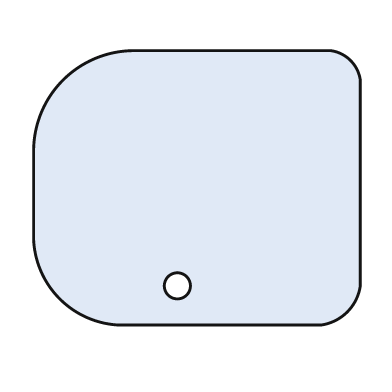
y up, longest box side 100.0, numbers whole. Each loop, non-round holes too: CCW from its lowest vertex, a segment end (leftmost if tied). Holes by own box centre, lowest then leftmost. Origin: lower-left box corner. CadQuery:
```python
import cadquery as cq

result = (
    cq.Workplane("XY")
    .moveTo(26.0, 0.0)
    .lineTo(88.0, 0.0)
    .threePointArc((96.0, 4.0), (100.0, 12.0))
    .lineTo(100.0, 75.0)
    .threePointArc((97.0, 81.0), (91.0, 84.0))
    .lineTo(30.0, 84.0)
    .threePointArc((9.0, 75.0), (0.0, 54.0))
    .lineTo(0.0, 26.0)
    .threePointArc((8.0, 8.0), (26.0, 0.0))
    .close()
    .moveTo(44.0, 12.0)
    .circle(4.0)
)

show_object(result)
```